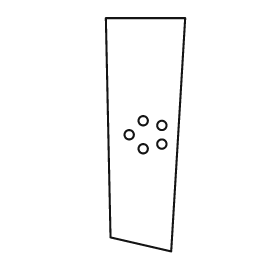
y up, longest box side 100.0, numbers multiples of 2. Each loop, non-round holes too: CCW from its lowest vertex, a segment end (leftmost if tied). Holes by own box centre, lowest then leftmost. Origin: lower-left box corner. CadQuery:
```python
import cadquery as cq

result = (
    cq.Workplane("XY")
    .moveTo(28.0, 0.0)
    .lineTo(34.0, 100.0)
    .lineTo(0.0, 100.0)
    .lineTo(2.0, 6.0)
    .close()
    .moveTo(16.0, 44.0)
    .circle(2.0)
    .moveTo(24.0, 46.0)
    .circle(2.0)
    .moveTo(10.0, 50.0)
    .circle(2.0)
    .moveTo(24.0, 54.0)
    .circle(2.0)
    .moveTo(16.0, 56.0)
    .circle(2.0)
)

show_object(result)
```